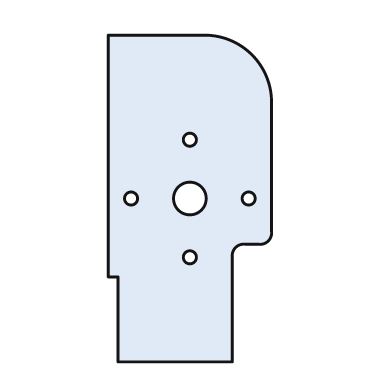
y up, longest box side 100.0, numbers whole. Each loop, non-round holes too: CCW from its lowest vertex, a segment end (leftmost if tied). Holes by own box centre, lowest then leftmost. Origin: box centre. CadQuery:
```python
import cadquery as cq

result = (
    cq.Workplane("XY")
    .moveTo(-22.0, -50.0)
    .lineTo(13.0, -50.0)
    .lineTo(13.0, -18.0)
    .threePointArc((14.0, -15.0), (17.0, -14.0))
    .lineTo(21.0, -14.0)
    .threePointArc((24.0, -13.0), (25.0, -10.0))
    .lineTo(25.0, 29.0)
    .threePointArc((19.0, 44.0), (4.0, 50.0))
    .lineTo(-25.0, 50.0)
    .lineTo(-25.0, -24.0)
    .lineTo(-22.0, -24.0)
    .close()
    .moveTo(0.0, -18.0)
    .circle(2.0)
    .moveTo(-18.0, 0.0)
    .circle(2.0)
    .moveTo(0.0, 0.0)
    .circle(5.0)
    .moveTo(18.0, 0.0)
    .circle(2.0)
    .moveTo(0.0, 18.0)
    .circle(2.0)
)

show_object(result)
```